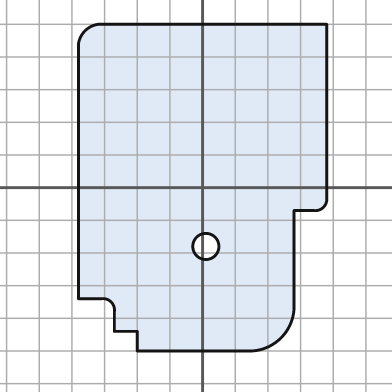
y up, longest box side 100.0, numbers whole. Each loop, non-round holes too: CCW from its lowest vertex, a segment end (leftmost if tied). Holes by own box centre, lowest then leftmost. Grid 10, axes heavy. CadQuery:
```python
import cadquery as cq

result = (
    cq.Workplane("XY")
    .moveTo(-20.0, -50.0)
    .lineTo(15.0, -50.0)
    .threePointArc((24.0, -46.0), (28.0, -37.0))
    .lineTo(28.0, -7.0)
    .lineTo(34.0, -7.0)
    .threePointArc((37.0, -6.0), (38.0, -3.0))
    .lineTo(38.0, 50.0)
    .lineTo(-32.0, 50.0)
    .threePointArc((-36.0, 48.0), (-38.0, 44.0))
    .lineTo(-38.0, -34.0)
    .lineTo(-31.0, -34.0)
    .threePointArc((-28.0, -35.0), (-27.0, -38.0))
    .lineTo(-27.0, -44.0)
    .lineTo(-20.0, -44.0)
    .close()
    .moveTo(1.0, -18.0)
    .circle(4.0)
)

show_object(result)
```